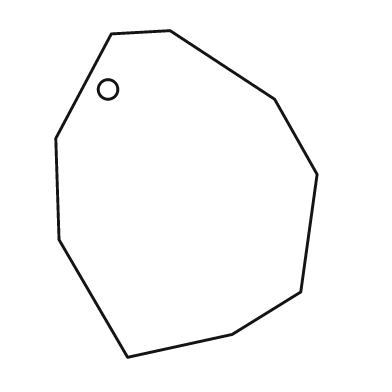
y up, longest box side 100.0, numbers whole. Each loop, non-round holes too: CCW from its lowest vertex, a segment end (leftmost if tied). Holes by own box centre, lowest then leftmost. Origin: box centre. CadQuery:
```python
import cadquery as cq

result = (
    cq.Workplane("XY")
    .moveTo(-18.0, -50.0)
    .lineTo(14.0, -43.0)
    .lineTo(35.0, -30.0)
    .lineTo(40.0, 6.0)
    .lineTo(27.0, 29.0)
    .lineTo(-5.0, 50.0)
    .lineTo(-23.0, 49.0)
    .lineTo(-40.0, 17.0)
    .lineTo(-39.0, -14.0)
    .close()
    .moveTo(-24.0, 32.0)
    .circle(3.0)
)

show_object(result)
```